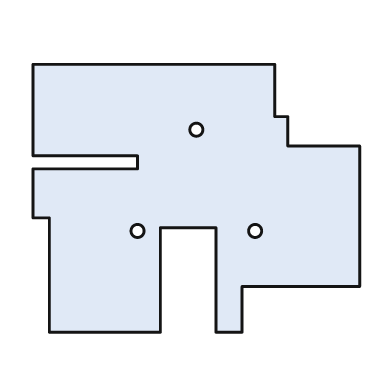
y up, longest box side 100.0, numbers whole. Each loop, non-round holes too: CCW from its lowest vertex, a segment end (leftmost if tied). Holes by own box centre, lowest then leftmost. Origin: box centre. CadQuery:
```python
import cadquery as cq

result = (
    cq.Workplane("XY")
    .moveTo(-45.0, -41.0)
    .lineTo(-11.0, -41.0)
    .lineTo(-11.0, -9.0)
    .lineTo(6.0, -9.0)
    .lineTo(6.0, -41.0)
    .lineTo(14.0, -41.0)
    .lineTo(14.0, -27.0)
    .lineTo(50.0, -27.0)
    .lineTo(50.0, 16.0)
    .lineTo(28.0, 16.0)
    .lineTo(28.0, 25.0)
    .lineTo(24.0, 25.0)
    .lineTo(24.0, 41.0)
    .lineTo(-50.0, 41.0)
    .lineTo(-50.0, 13.0)
    .lineTo(-18.0, 13.0)
    .lineTo(-18.0, 9.0)
    .lineTo(-50.0, 9.0)
    .lineTo(-50.0, -6.0)
    .lineTo(-45.0, -6.0)
    .close()
    .moveTo(-18.0, -10.0)
    .circle(2.0)
    .moveTo(18.0, -10.0)
    .circle(2.0)
    .moveTo(0.0, 21.0)
    .circle(2.0)
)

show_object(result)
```